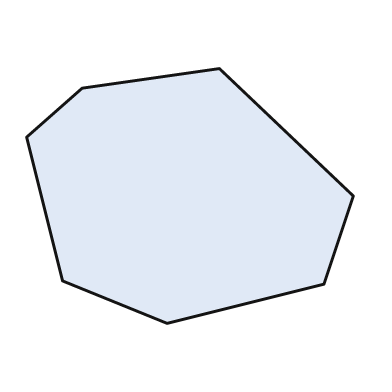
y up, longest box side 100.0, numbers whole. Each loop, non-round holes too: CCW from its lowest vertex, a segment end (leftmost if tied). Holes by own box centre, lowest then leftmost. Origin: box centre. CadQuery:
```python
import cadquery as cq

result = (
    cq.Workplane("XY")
    .moveTo(-7.0, -39.0)
    .lineTo(41.0, -27.0)
    .lineTo(50.0, 0.0)
    .lineTo(9.0, 39.0)
    .lineTo(-33.0, 33.0)
    .lineTo(-50.0, 18.0)
    .lineTo(-39.0, -26.0)
    .close()
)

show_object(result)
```